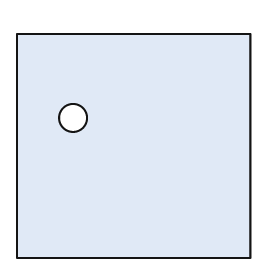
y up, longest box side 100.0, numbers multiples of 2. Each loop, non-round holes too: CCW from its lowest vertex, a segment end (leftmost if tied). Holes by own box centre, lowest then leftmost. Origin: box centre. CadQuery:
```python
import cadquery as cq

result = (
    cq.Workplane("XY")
    .moveTo(-50.0, -48.0)
    .lineTo(50.0, -48.0)
    .lineTo(50.0, 48.0)
    .lineTo(-50.0, 48.0)
    .close()
    .moveTo(-26.0, 12.0)
    .circle(6.0)
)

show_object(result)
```